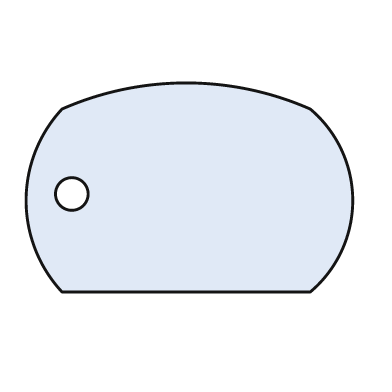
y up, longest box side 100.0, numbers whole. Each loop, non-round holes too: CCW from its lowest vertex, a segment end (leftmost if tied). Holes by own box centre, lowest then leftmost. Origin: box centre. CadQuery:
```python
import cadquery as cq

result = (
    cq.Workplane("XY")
    .moveTo(-39.0, -32.0)
    .lineTo(37.0, -32.0)
    .threePointArc((50.0, -4.0), (37.0, 24.0))
    .threePointArc((-1.0, 32.0), (-39.0, 24.0))
    .threePointArc((-50.0, -4.0), (-39.0, -32.0))
    .close()
    .moveTo(-36.0, -2.0)
    .circle(5.0)
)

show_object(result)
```